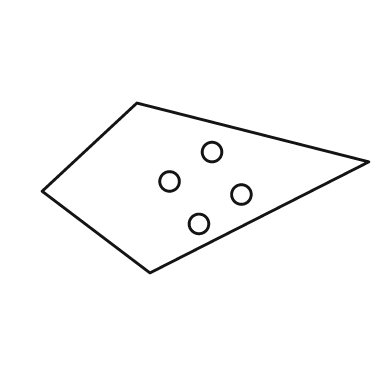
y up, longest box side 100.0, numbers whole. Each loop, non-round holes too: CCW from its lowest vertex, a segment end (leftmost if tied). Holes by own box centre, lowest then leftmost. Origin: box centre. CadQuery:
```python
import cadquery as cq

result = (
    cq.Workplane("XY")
    .moveTo(-17.0, -26.0)
    .lineTo(50.0, 8.0)
    .lineTo(-21.0, 26.0)
    .lineTo(-50.0, -1.0)
    .close()
    .moveTo(-2.0, -11.0)
    .circle(3.0)
    .moveTo(11.0, -2.0)
    .circle(3.0)
    .moveTo(-11.0, 2.0)
    .circle(3.0)
    .moveTo(2.0, 11.0)
    .circle(3.0)
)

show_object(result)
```